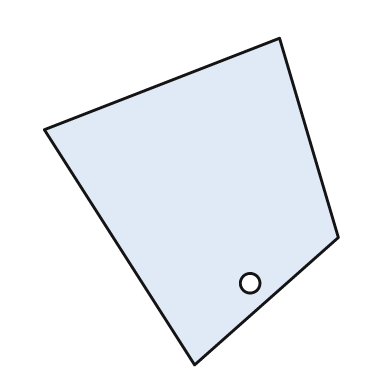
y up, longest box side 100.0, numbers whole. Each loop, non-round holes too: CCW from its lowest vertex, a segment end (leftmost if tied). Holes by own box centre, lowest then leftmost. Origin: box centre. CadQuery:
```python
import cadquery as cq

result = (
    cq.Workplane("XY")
    .moveTo(1.0, -50.0)
    .lineTo(45.0, -11.0)
    .lineTo(27.0, 50.0)
    .lineTo(-45.0, 22.0)
    .close()
    .moveTo(18.0, -25.0)
    .circle(3.0)
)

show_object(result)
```